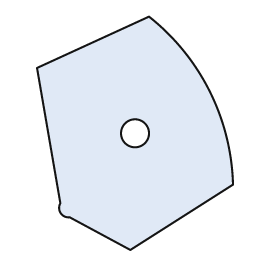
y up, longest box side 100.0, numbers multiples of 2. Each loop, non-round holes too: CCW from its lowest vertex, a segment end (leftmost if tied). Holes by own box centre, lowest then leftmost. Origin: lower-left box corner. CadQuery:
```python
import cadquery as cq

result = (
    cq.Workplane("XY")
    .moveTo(40.0, 0.0)
    .lineTo(84.0, 28.0)
    .threePointArc((74.0, 68.0), (48.0, 100.0))
    .lineTo(0.0, 78.0)
    .lineTo(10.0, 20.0)
    .threePointArc((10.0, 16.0), (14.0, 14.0))
    .close()
    .moveTo(42.0, 50.0)
    .circle(6.0)
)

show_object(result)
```